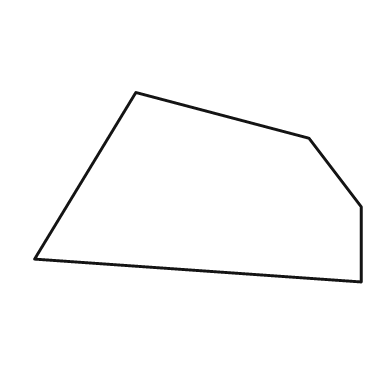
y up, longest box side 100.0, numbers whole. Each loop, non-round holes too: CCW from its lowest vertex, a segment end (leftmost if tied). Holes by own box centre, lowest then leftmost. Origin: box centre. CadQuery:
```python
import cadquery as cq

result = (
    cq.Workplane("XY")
    .moveTo(50.0, -29.0)
    .lineTo(50.0, -6.0)
    .lineTo(34.0, 15.0)
    .lineTo(-19.0, 29.0)
    .lineTo(-50.0, -22.0)
    .close()
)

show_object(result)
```